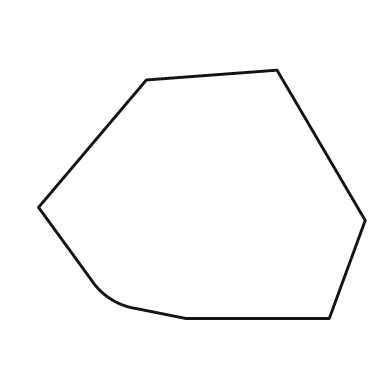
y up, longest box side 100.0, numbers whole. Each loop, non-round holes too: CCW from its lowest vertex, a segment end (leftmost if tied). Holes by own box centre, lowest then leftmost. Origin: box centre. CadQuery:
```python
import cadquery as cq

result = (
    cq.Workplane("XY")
    .moveTo(-5.0, -38.0)
    .lineTo(39.0, -38.0)
    .lineTo(50.0, -8.0)
    .lineTo(23.0, 38.0)
    .lineTo(-17.0, 35.0)
    .lineTo(-50.0, -4.0)
    .lineTo(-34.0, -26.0)
    .threePointArc((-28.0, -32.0), (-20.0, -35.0))
    .close()
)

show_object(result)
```